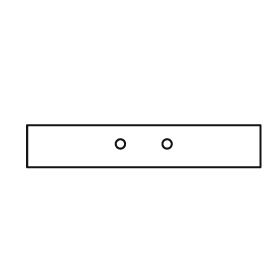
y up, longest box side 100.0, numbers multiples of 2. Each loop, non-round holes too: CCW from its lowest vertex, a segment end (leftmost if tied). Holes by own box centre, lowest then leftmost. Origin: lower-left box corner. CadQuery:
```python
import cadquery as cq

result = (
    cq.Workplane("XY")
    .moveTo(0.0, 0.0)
    .lineTo(100.0, 0.0)
    .lineTo(100.0, 18.0)
    .lineTo(0.0, 18.0)
    .close()
    .moveTo(40.0, 10.0)
    .circle(2.0)
    .moveTo(60.0, 10.0)
    .circle(2.0)
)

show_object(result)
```